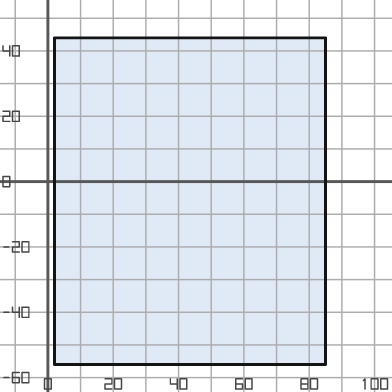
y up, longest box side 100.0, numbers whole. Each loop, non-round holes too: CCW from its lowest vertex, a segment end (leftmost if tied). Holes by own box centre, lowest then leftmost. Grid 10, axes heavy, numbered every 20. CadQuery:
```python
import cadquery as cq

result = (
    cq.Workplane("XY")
    .moveTo(2.0, -56.0)
    .lineTo(85.0, -56.0)
    .lineTo(85.0, 44.0)
    .lineTo(2.0, 44.0)
    .close()
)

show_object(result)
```